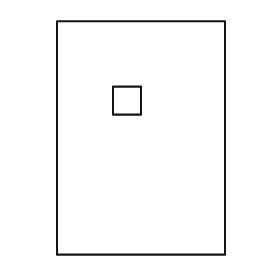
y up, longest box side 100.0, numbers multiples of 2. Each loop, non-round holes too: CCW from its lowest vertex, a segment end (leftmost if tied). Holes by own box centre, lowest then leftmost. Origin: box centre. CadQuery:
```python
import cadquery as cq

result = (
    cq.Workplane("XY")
    .moveTo(-36.0, -50.0)
    .lineTo(36.0, -50.0)
    .lineTo(36.0, 50.0)
    .lineTo(-36.0, 50.0)
    .close()
    .moveTo(-12.0, 10.0)
    .lineTo(0.0, 10.0)
    .lineTo(0.0, 22.0)
    .lineTo(-12.0, 22.0)
    .close()
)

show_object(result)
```